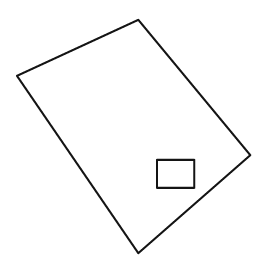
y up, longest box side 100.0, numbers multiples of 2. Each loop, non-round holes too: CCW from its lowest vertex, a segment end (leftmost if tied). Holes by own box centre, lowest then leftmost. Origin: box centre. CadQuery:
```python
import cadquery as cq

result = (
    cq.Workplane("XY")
    .moveTo(2.0, -50.0)
    .lineTo(50.0, -8.0)
    .lineTo(2.0, 50.0)
    .lineTo(-50.0, 26.0)
    .close()
    .moveTo(10.0, -22.0)
    .lineTo(26.0, -22.0)
    .lineTo(26.0, -10.0)
    .lineTo(10.0, -10.0)
    .close()
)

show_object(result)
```